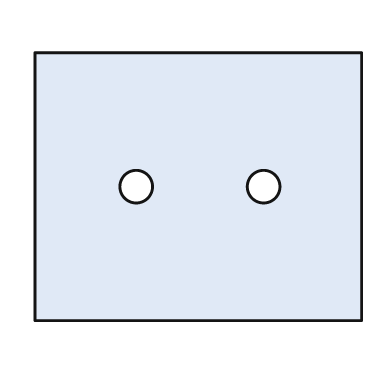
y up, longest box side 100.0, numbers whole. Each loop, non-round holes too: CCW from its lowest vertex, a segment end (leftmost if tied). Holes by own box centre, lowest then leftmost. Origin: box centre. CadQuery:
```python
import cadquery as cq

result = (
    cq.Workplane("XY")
    .moveTo(-50.0, -41.0)
    .lineTo(50.0, -41.0)
    .lineTo(50.0, 41.0)
    .lineTo(-50.0, 41.0)
    .close()
    .moveTo(-19.0, 0.0)
    .circle(5.0)
    .moveTo(20.0, 0.0)
    .circle(5.0)
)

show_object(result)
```